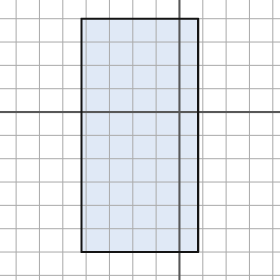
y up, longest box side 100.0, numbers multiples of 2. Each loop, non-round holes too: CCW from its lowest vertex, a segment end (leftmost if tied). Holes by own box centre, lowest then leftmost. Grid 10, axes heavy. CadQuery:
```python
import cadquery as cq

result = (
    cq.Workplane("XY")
    .moveTo(-42.0, -60.0)
    .lineTo(8.0, -60.0)
    .lineTo(8.0, 40.0)
    .lineTo(-42.0, 40.0)
    .close()
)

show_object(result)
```